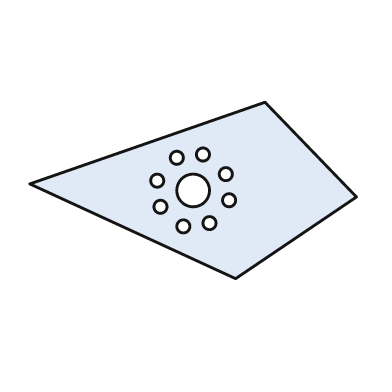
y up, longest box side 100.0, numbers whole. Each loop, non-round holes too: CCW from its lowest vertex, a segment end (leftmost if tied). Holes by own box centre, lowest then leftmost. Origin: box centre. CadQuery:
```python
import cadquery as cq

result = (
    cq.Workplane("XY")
    .moveTo(13.0, -27.0)
    .lineTo(50.0, -2.0)
    .lineTo(22.0, 27.0)
    .lineTo(-50.0, 2.0)
    .close()
    .moveTo(-3.0, -11.0)
    .circle(2.0)
    .moveTo(5.0, -10.0)
    .circle(2.0)
    .moveTo(-10.0, -5.0)
    .circle(2.0)
    .moveTo(11.0, -3.0)
    .circle(2.0)
    .moveTo(0.0, 0.0)
    .circle(5.0)
    .moveTo(-11.0, 3.0)
    .circle(2.0)
    .moveTo(10.0, 5.0)
    .circle(2.0)
    .moveTo(-5.0, 10.0)
    .circle(2.0)
    .moveTo(3.0, 11.0)
    .circle(2.0)
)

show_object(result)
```